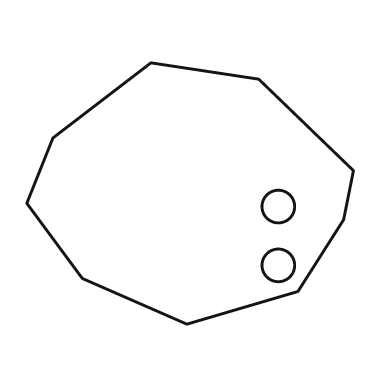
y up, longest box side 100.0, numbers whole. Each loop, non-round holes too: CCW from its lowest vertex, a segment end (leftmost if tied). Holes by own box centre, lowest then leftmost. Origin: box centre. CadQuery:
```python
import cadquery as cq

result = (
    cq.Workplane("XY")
    .moveTo(-1.0, -40.0)
    .lineTo(33.0, -30.0)
    .lineTo(47.0, -8.0)
    .lineTo(50.0, 7.0)
    .lineTo(21.0, 35.0)
    .lineTo(-12.0, 40.0)
    .lineTo(-42.0, 17.0)
    .lineTo(-50.0, -3.0)
    .lineTo(-33.0, -26.0)
    .close()
    .moveTo(27.0, -22.0)
    .circle(5.0)
    .moveTo(27.0, -4.0)
    .circle(5.0)
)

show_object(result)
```